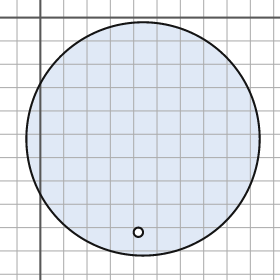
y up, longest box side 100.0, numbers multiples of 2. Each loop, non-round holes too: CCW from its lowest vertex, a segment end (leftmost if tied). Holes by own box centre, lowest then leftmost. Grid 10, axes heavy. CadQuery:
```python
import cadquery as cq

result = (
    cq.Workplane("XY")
    .moveTo(44.0, -52.0)
    .circle(50.0)
    .moveTo(42.0, -92.0)
    .circle(2.0)
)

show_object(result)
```